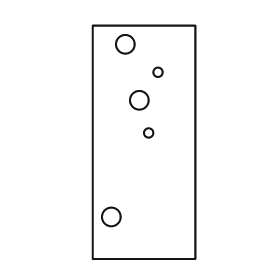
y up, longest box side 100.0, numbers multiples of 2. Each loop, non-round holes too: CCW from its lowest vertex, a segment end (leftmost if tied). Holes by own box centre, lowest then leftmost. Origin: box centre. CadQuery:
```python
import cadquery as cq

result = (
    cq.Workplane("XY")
    .moveTo(-22.0, -50.0)
    .lineTo(22.0, -50.0)
    .lineTo(22.0, 50.0)
    .lineTo(-22.0, 50.0)
    .close()
    .moveTo(-14.0, -32.0)
    .circle(4.0)
    .moveTo(2.0, 4.0)
    .circle(2.0)
    .moveTo(-2.0, 18.0)
    .circle(4.0)
    .moveTo(6.0, 30.0)
    .circle(2.0)
    .moveTo(-8.0, 42.0)
    .circle(4.0)
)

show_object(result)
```